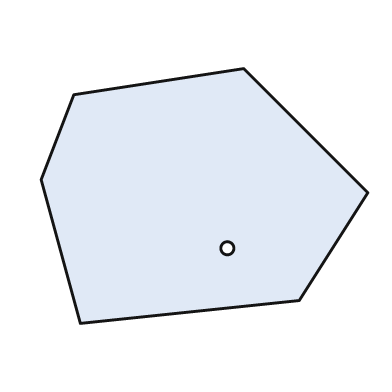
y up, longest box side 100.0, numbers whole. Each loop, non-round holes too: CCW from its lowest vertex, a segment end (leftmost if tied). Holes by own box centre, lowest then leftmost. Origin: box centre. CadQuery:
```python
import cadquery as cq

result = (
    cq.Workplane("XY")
    .moveTo(-38.0, -39.0)
    .lineTo(29.0, -32.0)
    .lineTo(50.0, 1.0)
    .lineTo(12.0, 39.0)
    .lineTo(-40.0, 31.0)
    .lineTo(-50.0, 5.0)
    .close()
    .moveTo(7.0, -16.0)
    .circle(2.0)
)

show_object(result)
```